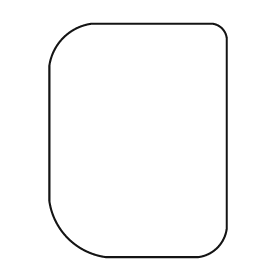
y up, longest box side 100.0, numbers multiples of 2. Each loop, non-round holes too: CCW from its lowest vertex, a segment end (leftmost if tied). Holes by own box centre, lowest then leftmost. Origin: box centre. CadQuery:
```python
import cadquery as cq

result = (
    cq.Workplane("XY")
    .moveTo(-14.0, -50.0)
    .lineTo(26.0, -50.0)
    .threePointArc((34.0, -46.0), (38.0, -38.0))
    .lineTo(38.0, 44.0)
    .threePointArc((36.0, 48.0), (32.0, 50.0))
    .lineTo(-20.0, 50.0)
    .threePointArc((-32.0, 44.0), (-38.0, 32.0))
    .lineTo(-38.0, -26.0)
    .threePointArc((-30.0, -42.0), (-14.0, -50.0))
    .close()
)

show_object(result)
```